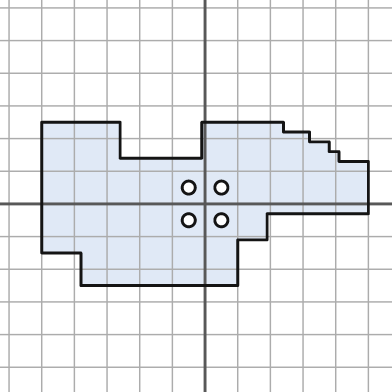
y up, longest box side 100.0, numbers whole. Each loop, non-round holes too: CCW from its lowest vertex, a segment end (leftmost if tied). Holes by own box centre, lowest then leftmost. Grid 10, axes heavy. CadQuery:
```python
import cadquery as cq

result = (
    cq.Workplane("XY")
    .moveTo(-38.0, -25.0)
    .lineTo(10.0, -25.0)
    .lineTo(10.0, -11.0)
    .lineTo(19.0, -11.0)
    .lineTo(19.0, -3.0)
    .lineTo(50.0, -3.0)
    .lineTo(50.0, 13.0)
    .lineTo(41.0, 13.0)
    .lineTo(41.0, 16.0)
    .lineTo(38.0, 16.0)
    .lineTo(38.0, 19.0)
    .lineTo(32.0, 19.0)
    .lineTo(32.0, 22.0)
    .lineTo(24.0, 22.0)
    .lineTo(24.0, 25.0)
    .lineTo(-1.0, 25.0)
    .lineTo(-1.0, 14.0)
    .lineTo(-26.0, 14.0)
    .lineTo(-26.0, 25.0)
    .lineTo(-50.0, 25.0)
    .lineTo(-50.0, -15.0)
    .lineTo(-38.0, -15.0)
    .close()
    .moveTo(-5.0, -5.0)
    .circle(2.0)
    .moveTo(5.0, -5.0)
    .circle(2.0)
    .moveTo(-5.0, 5.0)
    .circle(2.0)
    .moveTo(5.0, 5.0)
    .circle(2.0)
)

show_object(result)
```